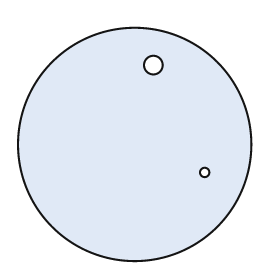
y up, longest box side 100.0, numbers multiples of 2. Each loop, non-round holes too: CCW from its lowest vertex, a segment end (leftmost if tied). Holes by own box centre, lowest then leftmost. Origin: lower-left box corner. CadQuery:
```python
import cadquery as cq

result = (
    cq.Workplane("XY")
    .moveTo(50.0, 50.0)
    .circle(50.0)
    .moveTo(80.0, 38.0)
    .circle(2.0)
    .moveTo(58.0, 84.0)
    .circle(4.0)
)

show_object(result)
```